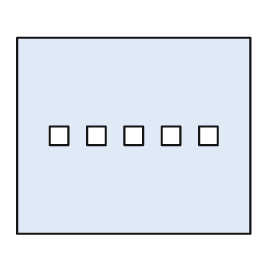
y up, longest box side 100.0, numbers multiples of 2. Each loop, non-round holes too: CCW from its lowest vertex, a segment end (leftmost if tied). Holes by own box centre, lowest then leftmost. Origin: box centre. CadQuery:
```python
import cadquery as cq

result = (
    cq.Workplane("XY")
    .moveTo(-50.0, -42.0)
    .lineTo(50.0, -42.0)
    .lineTo(50.0, 42.0)
    .lineTo(-50.0, 42.0)
    .close()
    .moveTo(-36.0, -4.0)
    .lineTo(-28.0, -4.0)
    .lineTo(-28.0, 4.0)
    .lineTo(-36.0, 4.0)
    .close()
    .moveTo(-20.0, -4.0)
    .lineTo(-12.0, -4.0)
    .lineTo(-12.0, 4.0)
    .lineTo(-20.0, 4.0)
    .close()
    .moveTo(-4.0, -4.0)
    .lineTo(4.0, -4.0)
    .lineTo(4.0, 4.0)
    .lineTo(-4.0, 4.0)
    .close()
    .moveTo(12.0, -4.0)
    .lineTo(20.0, -4.0)
    .lineTo(20.0, 4.0)
    .lineTo(12.0, 4.0)
    .close()
    .moveTo(28.0, -4.0)
    .lineTo(36.0, -4.0)
    .lineTo(36.0, 4.0)
    .lineTo(28.0, 4.0)
    .close()
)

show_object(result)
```